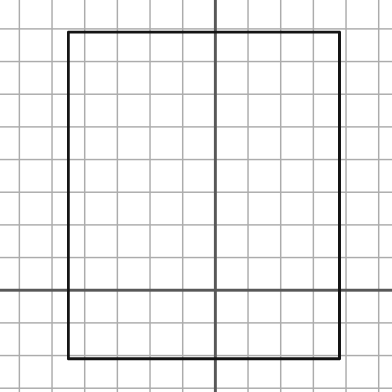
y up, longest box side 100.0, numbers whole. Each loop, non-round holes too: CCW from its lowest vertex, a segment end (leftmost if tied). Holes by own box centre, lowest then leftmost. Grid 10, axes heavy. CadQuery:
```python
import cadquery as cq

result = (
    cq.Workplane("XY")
    .moveTo(-45.0, -21.0)
    .lineTo(38.0, -21.0)
    .lineTo(38.0, 79.0)
    .lineTo(-45.0, 79.0)
    .close()
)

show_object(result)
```